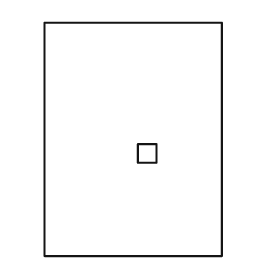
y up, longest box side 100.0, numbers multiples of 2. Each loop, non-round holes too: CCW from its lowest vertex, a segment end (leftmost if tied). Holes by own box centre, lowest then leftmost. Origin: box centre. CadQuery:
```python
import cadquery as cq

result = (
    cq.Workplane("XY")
    .moveTo(-38.0, -50.0)
    .lineTo(38.0, -50.0)
    .lineTo(38.0, 50.0)
    .lineTo(-38.0, 50.0)
    .close()
    .moveTo(2.0, -10.0)
    .lineTo(10.0, -10.0)
    .lineTo(10.0, -2.0)
    .lineTo(2.0, -2.0)
    .close()
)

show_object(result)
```